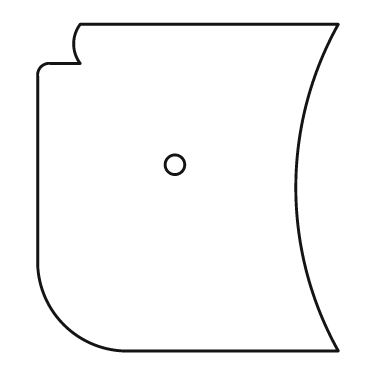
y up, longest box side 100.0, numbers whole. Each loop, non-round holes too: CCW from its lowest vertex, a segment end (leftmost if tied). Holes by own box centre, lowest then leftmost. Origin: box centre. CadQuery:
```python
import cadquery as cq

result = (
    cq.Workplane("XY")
    .moveTo(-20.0, -50.0)
    .lineTo(46.0, -50.0)
    .threePointArc((33.0, 0.0), (46.0, 50.0))
    .lineTo(-33.0, 50.0)
    .threePointArc((-35.0, 44.0), (-33.0, 38.0))
    .lineTo(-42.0, 38.0)
    .threePointArc((-45.0, 37.0), (-46.0, 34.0))
    .lineTo(-46.0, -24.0)
    .threePointArc((-38.0, -42.0), (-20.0, -50.0))
    .close()
    .moveTo(-4.0, 7.0)
    .circle(3.0)
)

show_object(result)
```